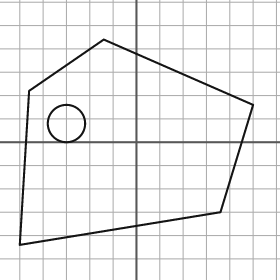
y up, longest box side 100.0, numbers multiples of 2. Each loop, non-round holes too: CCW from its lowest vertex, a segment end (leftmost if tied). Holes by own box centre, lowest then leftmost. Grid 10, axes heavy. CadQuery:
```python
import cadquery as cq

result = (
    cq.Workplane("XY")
    .moveTo(-50.0, -44.0)
    .lineTo(36.0, -30.0)
    .lineTo(50.0, 16.0)
    .lineTo(-14.0, 44.0)
    .lineTo(-46.0, 22.0)
    .close()
    .moveTo(-30.0, 8.0)
    .circle(8.0)
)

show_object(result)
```